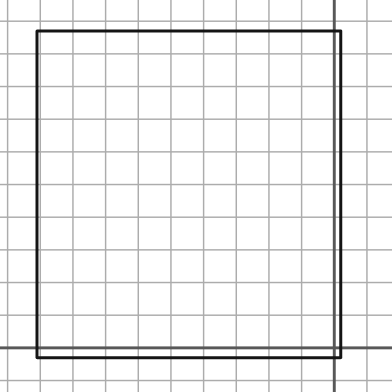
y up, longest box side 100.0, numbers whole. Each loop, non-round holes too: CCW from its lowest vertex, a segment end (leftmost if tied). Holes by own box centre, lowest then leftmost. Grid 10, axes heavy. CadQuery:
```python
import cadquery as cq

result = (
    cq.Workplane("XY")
    .moveTo(-91.0, -3.0)
    .lineTo(2.0, -3.0)
    .lineTo(2.0, 97.0)
    .lineTo(-91.0, 97.0)
    .close()
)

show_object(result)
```